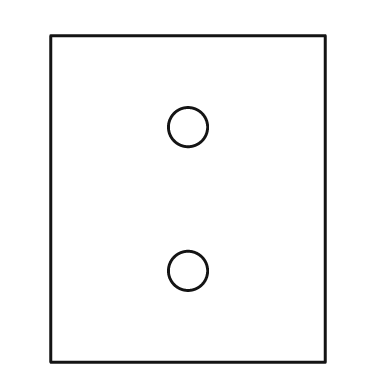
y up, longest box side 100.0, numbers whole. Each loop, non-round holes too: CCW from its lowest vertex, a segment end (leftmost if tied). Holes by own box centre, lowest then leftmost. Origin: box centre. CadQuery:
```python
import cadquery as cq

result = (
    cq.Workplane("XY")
    .moveTo(-42.0, -50.0)
    .lineTo(42.0, -50.0)
    .lineTo(42.0, 50.0)
    .lineTo(-42.0, 50.0)
    .close()
    .moveTo(0.0, -22.0)
    .circle(6.0)
    .moveTo(0.0, 22.0)
    .circle(6.0)
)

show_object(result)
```